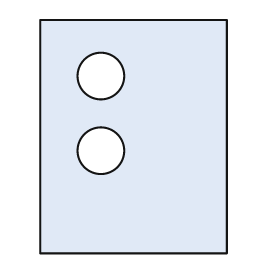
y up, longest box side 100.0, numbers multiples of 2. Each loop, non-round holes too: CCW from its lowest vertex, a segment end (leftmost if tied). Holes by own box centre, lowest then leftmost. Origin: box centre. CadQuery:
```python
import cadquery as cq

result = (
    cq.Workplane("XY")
    .moveTo(-40.0, -50.0)
    .lineTo(40.0, -50.0)
    .lineTo(40.0, 50.0)
    .lineTo(-40.0, 50.0)
    .close()
    .moveTo(-14.0, -6.0)
    .circle(10.0)
    .moveTo(-14.0, 26.0)
    .circle(10.0)
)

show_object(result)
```